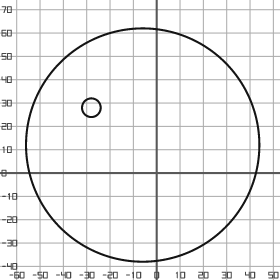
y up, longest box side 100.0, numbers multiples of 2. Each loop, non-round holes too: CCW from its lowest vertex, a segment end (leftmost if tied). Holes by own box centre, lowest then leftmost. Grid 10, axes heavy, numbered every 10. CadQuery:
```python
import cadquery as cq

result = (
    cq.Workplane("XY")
    .moveTo(-6.0, 12.0)
    .circle(50.0)
    .moveTo(-28.0, 28.0)
    .circle(4.0)
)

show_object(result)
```